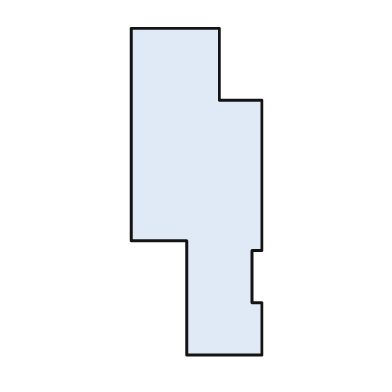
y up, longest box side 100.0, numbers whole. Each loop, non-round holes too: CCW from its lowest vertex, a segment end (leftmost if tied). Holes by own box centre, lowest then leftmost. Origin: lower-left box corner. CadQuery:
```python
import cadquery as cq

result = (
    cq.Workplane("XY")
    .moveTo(17.0, 0.0)
    .lineTo(40.0, 0.0)
    .lineTo(40.0, 16.0)
    .lineTo(37.0, 16.0)
    .lineTo(37.0, 32.0)
    .lineTo(40.0, 32.0)
    .lineTo(40.0, 78.0)
    .lineTo(27.0, 78.0)
    .lineTo(27.0, 100.0)
    .lineTo(0.0, 100.0)
    .lineTo(0.0, 35.0)
    .lineTo(17.0, 35.0)
    .close()
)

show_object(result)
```